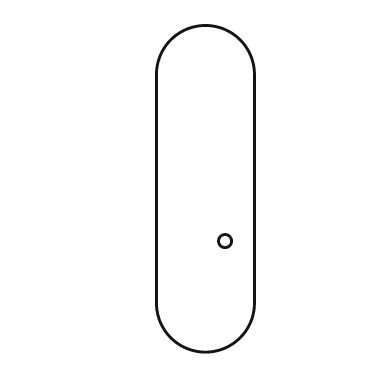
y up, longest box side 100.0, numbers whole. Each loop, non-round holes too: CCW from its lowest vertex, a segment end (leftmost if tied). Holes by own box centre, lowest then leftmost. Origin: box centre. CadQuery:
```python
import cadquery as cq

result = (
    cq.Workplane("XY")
    .moveTo(-15.0, -35.0)
    .threePointArc((0.0, -50.0), (15.0, -35.0))
    .lineTo(15.0, 35.0)
    .threePointArc((0.0, 50.0), (-15.0, 35.0))
    .close()
    .moveTo(6.0, -16.0)
    .circle(2.0)
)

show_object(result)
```